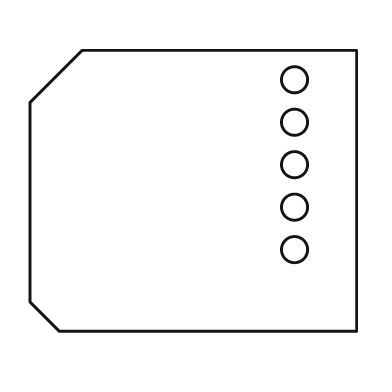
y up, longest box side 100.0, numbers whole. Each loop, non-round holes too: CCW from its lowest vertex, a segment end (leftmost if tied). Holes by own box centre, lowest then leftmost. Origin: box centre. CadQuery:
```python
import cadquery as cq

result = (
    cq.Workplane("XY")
    .moveTo(-41.0, -43.0)
    .lineTo(50.0, -43.0)
    .lineTo(50.0, 43.0)
    .lineTo(-34.0, 43.0)
    .lineTo(-50.0, 27.0)
    .lineTo(-50.0, -34.0)
    .close()
    .moveTo(31.0, -18.0)
    .circle(4.0)
    .moveTo(31.0, -5.0)
    .circle(4.0)
    .moveTo(31.0, 8.0)
    .circle(4.0)
    .moveTo(31.0, 21.0)
    .circle(4.0)
    .moveTo(31.0, 34.0)
    .circle(4.0)
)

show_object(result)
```